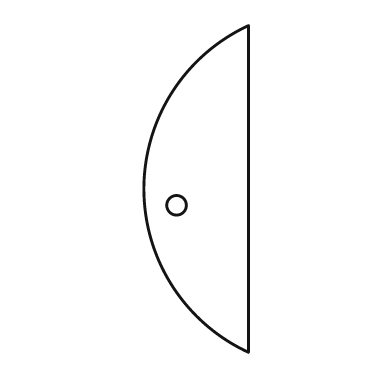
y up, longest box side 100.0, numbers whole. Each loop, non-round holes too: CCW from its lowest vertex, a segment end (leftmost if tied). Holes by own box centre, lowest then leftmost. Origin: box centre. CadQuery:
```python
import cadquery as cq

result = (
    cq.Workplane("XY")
    .moveTo(16.0, -50.0)
    .lineTo(16.0, 50.0)
    .threePointArc((-16.0, 0.0), (16.0, -50.0))
    .close()
    .moveTo(-6.0, -5.0)
    .circle(3.0)
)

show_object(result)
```